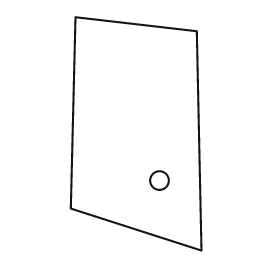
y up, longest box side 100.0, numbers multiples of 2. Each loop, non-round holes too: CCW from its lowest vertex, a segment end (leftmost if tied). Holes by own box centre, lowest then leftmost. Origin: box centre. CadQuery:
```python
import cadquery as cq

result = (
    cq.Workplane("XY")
    .moveTo(28.0, -50.0)
    .lineTo(26.0, 44.0)
    .lineTo(-26.0, 50.0)
    .lineTo(-28.0, -32.0)
    .close()
    .moveTo(10.0, -20.0)
    .circle(4.0)
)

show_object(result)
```